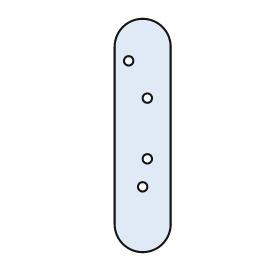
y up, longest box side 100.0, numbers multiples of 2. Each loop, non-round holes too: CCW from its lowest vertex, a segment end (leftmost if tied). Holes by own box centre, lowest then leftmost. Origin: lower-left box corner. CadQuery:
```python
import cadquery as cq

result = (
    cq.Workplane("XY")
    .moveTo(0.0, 12.0)
    .threePointArc((12.0, 0.0), (24.0, 12.0))
    .lineTo(24.0, 88.0)
    .threePointArc((12.0, 100.0), (0.0, 88.0))
    .close()
    .moveTo(12.0, 28.0)
    .circle(2.0)
    .moveTo(14.0, 40.0)
    .circle(2.0)
    .moveTo(14.0, 66.0)
    .circle(2.0)
    .moveTo(6.0, 82.0)
    .circle(2.0)
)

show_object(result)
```